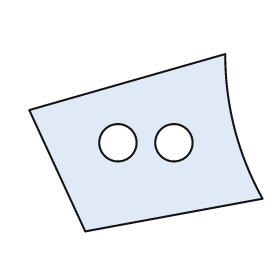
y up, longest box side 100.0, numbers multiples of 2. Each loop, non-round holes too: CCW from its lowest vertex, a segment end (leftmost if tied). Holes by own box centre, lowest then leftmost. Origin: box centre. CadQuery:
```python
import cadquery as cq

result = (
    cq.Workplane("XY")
    .moveTo(-26.0, -38.0)
    .lineTo(50.0, -24.0)
    .threePointArc((38.0, 6.0), (34.0, 38.0))
    .lineTo(-50.0, 14.0)
    .close()
    .moveTo(-12.0, 0.0)
    .circle(8.0)
    .moveTo(12.0, 0.0)
    .circle(8.0)
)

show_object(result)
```